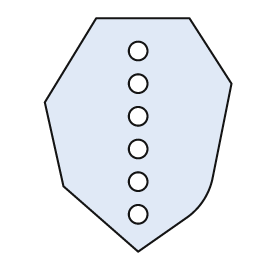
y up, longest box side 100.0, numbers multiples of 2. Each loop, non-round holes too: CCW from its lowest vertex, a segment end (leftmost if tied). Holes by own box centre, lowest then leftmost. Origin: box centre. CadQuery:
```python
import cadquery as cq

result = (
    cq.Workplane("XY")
    .moveTo(0.0, -50.0)
    .lineTo(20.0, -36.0)
    .threePointArc((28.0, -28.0), (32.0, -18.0))
    .lineTo(40.0, 22.0)
    .lineTo(22.0, 50.0)
    .lineTo(-18.0, 50.0)
    .lineTo(-40.0, 14.0)
    .lineTo(-32.0, -22.0)
    .close()
    .moveTo(0.0, -34.0)
    .circle(4.0)
    .moveTo(0.0, -20.0)
    .circle(4.0)
    .moveTo(0.0, -6.0)
    .circle(4.0)
    .moveTo(0.0, 8.0)
    .circle(4.0)
    .moveTo(0.0, 22.0)
    .circle(4.0)
    .moveTo(0.0, 36.0)
    .circle(4.0)
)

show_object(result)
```